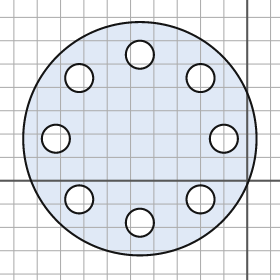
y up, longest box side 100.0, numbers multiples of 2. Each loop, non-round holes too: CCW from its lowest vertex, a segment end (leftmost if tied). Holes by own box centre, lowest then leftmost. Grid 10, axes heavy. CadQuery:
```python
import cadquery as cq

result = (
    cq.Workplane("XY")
    .moveTo(-46.0, 18.0)
    .circle(50.0)
    .moveTo(-46.0, -18.0)
    .circle(6.0)
    .moveTo(-72.0, -8.0)
    .circle(6.0)
    .moveTo(-20.0, -8.0)
    .circle(6.0)
    .moveTo(-82.0, 18.0)
    .circle(6.0)
    .moveTo(-10.0, 18.0)
    .circle(6.0)
    .moveTo(-72.0, 44.0)
    .circle(6.0)
    .moveTo(-20.0, 44.0)
    .circle(6.0)
    .moveTo(-46.0, 54.0)
    .circle(6.0)
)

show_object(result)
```